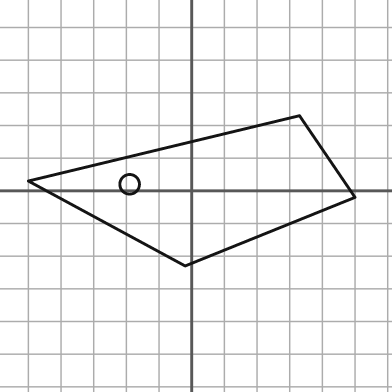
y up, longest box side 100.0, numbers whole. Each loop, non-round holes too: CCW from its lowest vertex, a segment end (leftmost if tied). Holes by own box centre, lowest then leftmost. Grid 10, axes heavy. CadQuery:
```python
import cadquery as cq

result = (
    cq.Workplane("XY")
    .moveTo(-2.0, -23.0)
    .lineTo(50.0, -2.0)
    .lineTo(33.0, 23.0)
    .lineTo(-50.0, 3.0)
    .close()
    .moveTo(-19.0, 2.0)
    .circle(3.0)
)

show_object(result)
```